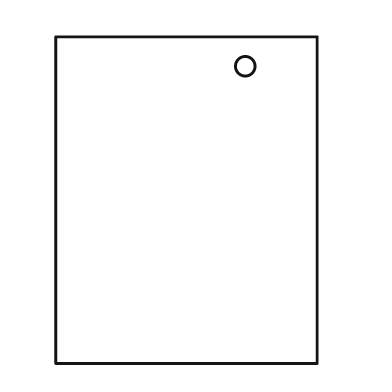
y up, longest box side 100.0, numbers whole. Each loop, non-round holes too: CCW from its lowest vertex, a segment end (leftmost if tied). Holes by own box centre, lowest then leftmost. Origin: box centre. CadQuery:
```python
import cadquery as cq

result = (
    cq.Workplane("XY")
    .moveTo(-40.0, -50.0)
    .lineTo(40.0, -50.0)
    .lineTo(40.0, 50.0)
    .lineTo(-40.0, 50.0)
    .close()
    .moveTo(18.0, 41.0)
    .circle(3.0)
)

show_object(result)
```